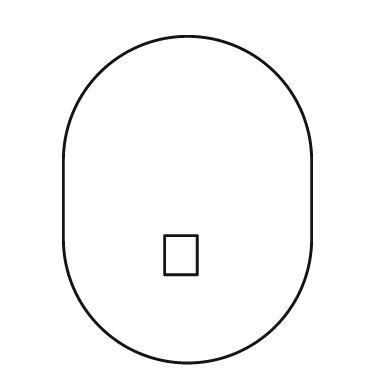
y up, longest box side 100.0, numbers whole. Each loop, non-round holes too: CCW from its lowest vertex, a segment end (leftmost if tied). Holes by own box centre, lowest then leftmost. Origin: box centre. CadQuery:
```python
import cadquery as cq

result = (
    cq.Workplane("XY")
    .moveTo(-38.0, -12.0)
    .threePointArc((0.0, -50.0), (38.0, -12.0))
    .lineTo(38.0, 12.0)
    .threePointArc((0.0, 50.0), (-38.0, 12.0))
    .close()
    .moveTo(-7.0, -23.0)
    .lineTo(3.0, -23.0)
    .lineTo(3.0, -11.0)
    .lineTo(-7.0, -11.0)
    .close()
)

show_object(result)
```